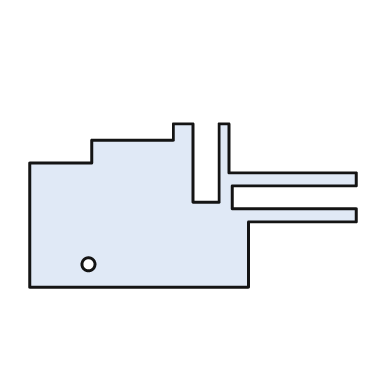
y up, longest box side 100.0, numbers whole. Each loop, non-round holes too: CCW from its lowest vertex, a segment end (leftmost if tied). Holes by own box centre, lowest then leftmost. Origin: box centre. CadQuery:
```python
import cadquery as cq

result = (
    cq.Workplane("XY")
    .moveTo(-50.0, -25.0)
    .lineTo(17.0, -25.0)
    .lineTo(17.0, -5.0)
    .lineTo(50.0, -5.0)
    .lineTo(50.0, -1.0)
    .lineTo(12.0, -1.0)
    .lineTo(12.0, 6.0)
    .lineTo(50.0, 6.0)
    .lineTo(50.0, 10.0)
    .lineTo(11.0, 10.0)
    .lineTo(11.0, 25.0)
    .lineTo(8.0, 25.0)
    .lineTo(8.0, 1.0)
    .lineTo(0.0, 1.0)
    .lineTo(0.0, 25.0)
    .lineTo(-6.0, 25.0)
    .lineTo(-6.0, 20.0)
    .lineTo(-31.0, 20.0)
    .lineTo(-31.0, 13.0)
    .lineTo(-50.0, 13.0)
    .close()
    .moveTo(-32.0, -18.0)
    .circle(2.0)
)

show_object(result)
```